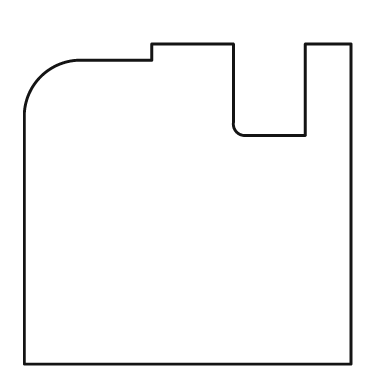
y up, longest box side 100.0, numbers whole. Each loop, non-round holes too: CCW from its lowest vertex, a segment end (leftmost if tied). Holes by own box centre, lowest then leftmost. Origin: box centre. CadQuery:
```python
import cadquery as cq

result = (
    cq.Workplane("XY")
    .moveTo(-50.0, -49.0)
    .lineTo(50.0, -49.0)
    .lineTo(50.0, 49.0)
    .lineTo(36.0, 49.0)
    .lineTo(36.0, 21.0)
    .lineTo(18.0, 21.0)
    .threePointArc((15.0, 22.0), (14.0, 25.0))
    .lineTo(14.0, 49.0)
    .lineTo(-11.0, 49.0)
    .lineTo(-11.0, 44.0)
    .lineTo(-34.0, 44.0)
    .threePointArc((-45.0, 39.0), (-50.0, 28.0))
    .close()
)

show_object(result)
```